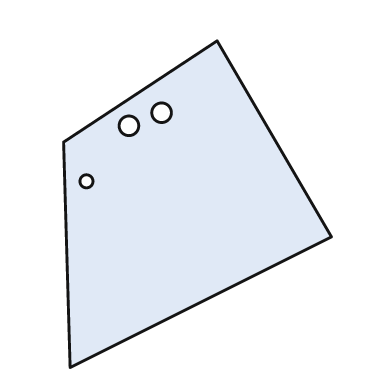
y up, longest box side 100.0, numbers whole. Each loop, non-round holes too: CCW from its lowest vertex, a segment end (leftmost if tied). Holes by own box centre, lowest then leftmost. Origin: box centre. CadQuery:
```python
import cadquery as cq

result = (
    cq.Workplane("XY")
    .moveTo(-39.0, -50.0)
    .lineTo(41.0, -10.0)
    .lineTo(6.0, 50.0)
    .lineTo(-41.0, 19.0)
    .close()
    .moveTo(-34.0, 7.0)
    .circle(2.0)
    .moveTo(-21.0, 24.0)
    .circle(3.0)
    .moveTo(-11.0, 28.0)
    .circle(3.0)
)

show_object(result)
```